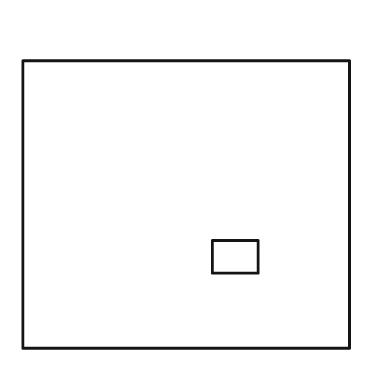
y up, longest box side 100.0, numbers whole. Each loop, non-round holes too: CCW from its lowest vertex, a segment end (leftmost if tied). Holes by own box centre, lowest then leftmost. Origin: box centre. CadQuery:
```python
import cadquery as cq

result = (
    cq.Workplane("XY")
    .moveTo(-50.0, -44.0)
    .lineTo(50.0, -44.0)
    .lineTo(50.0, 44.0)
    .lineTo(-50.0, 44.0)
    .close()
    .moveTo(8.0, -21.0)
    .lineTo(22.0, -21.0)
    .lineTo(22.0, -11.0)
    .lineTo(8.0, -11.0)
    .close()
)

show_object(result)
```